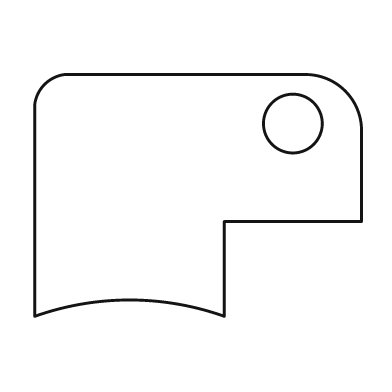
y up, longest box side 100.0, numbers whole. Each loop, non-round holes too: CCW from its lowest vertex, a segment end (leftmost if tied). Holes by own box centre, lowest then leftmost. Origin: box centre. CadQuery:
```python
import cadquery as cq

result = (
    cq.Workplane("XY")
    .moveTo(-50.0, -37.0)
    .threePointArc((-21.0, -32.0), (8.0, -37.0))
    .lineTo(8.0, -8.0)
    .lineTo(50.0, -8.0)
    .lineTo(50.0, 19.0)
    .threePointArc((45.0, 32.0), (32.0, 37.0))
    .lineTo(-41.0, 37.0)
    .threePointArc((-47.0, 34.0), (-50.0, 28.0))
    .close()
    .moveTo(29.0, 22.0)
    .circle(9.0)
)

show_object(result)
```